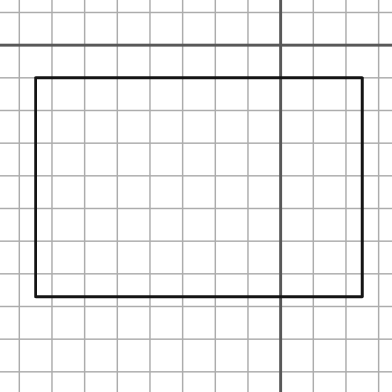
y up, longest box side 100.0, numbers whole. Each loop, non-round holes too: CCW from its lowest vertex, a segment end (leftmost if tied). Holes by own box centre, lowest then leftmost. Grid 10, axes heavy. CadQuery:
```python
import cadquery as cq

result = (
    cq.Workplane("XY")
    .moveTo(-75.0, -77.0)
    .lineTo(25.0, -77.0)
    .lineTo(25.0, -10.0)
    .lineTo(-75.0, -10.0)
    .close()
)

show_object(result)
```